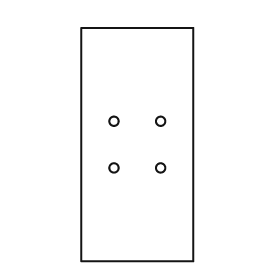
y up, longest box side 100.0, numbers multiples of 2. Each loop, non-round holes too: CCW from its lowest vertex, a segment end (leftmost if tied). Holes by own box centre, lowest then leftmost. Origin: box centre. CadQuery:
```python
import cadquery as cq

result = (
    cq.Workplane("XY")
    .moveTo(-24.0, -50.0)
    .lineTo(24.0, -50.0)
    .lineTo(24.0, 50.0)
    .lineTo(-24.0, 50.0)
    .close()
    .moveTo(-10.0, -10.0)
    .circle(2.0)
    .moveTo(10.0, -10.0)
    .circle(2.0)
    .moveTo(-10.0, 10.0)
    .circle(2.0)
    .moveTo(10.0, 10.0)
    .circle(2.0)
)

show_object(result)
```